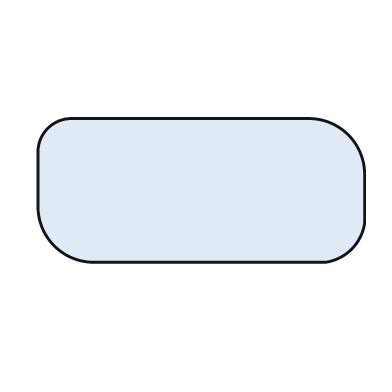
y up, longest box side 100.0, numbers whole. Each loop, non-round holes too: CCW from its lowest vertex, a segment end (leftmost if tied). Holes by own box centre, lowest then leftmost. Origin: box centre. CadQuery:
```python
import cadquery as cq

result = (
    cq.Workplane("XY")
    .moveTo(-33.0, -22.0)
    .lineTo(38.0, -22.0)
    .threePointArc((46.0, -18.0), (50.0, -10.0))
    .lineTo(50.0, 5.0)
    .threePointArc((45.0, 17.0), (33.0, 22.0))
    .lineTo(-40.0, 22.0)
    .threePointArc((-47.0, 19.0), (-50.0, 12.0))
    .lineTo(-50.0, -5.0)
    .threePointArc((-45.0, -17.0), (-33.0, -22.0))
    .close()
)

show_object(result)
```